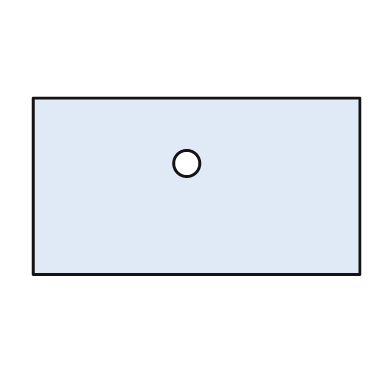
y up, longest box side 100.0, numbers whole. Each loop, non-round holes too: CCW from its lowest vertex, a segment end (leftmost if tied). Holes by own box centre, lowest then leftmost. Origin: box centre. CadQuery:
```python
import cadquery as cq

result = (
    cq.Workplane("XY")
    .moveTo(-50.0, -27.0)
    .lineTo(50.0, -27.0)
    .lineTo(50.0, 27.0)
    .lineTo(-50.0, 27.0)
    .close()
    .moveTo(-3.0, 7.0)
    .circle(4.0)
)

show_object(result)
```